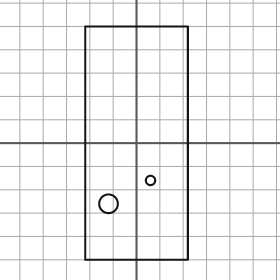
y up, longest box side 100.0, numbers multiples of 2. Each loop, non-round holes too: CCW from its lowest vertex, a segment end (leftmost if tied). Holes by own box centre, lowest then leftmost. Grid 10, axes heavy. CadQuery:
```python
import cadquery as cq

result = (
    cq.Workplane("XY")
    .moveTo(-22.0, -50.0)
    .lineTo(22.0, -50.0)
    .lineTo(22.0, 50.0)
    .lineTo(-22.0, 50.0)
    .close()
    .moveTo(-12.0, -26.0)
    .circle(4.0)
    .moveTo(6.0, -16.0)
    .circle(2.0)
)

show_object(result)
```